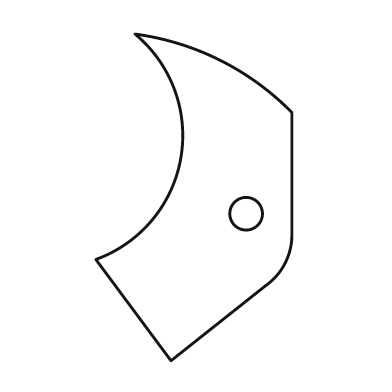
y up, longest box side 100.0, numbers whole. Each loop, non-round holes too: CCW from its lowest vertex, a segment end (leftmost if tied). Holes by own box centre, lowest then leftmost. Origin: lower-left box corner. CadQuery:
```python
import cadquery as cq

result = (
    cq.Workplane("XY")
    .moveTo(23.0, 0.0)
    .lineTo(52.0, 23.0)
    .threePointArc((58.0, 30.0), (60.0, 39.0))
    .lineTo(60.0, 76.0)
    .threePointArc((38.0, 92.0), (12.0, 100.0))
    .threePointArc((26.0, 62.0), (0.0, 31.0))
    .close()
    .moveTo(46.0, 45.0)
    .circle(5.0)
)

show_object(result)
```